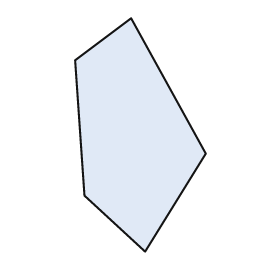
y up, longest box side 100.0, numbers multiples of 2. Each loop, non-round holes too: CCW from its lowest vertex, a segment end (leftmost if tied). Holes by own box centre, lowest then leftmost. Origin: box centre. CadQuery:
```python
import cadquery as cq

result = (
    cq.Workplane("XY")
    .moveTo(2.0, -50.0)
    .lineTo(28.0, -8.0)
    .lineTo(-4.0, 50.0)
    .lineTo(-28.0, 32.0)
    .lineTo(-24.0, -26.0)
    .close()
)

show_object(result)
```